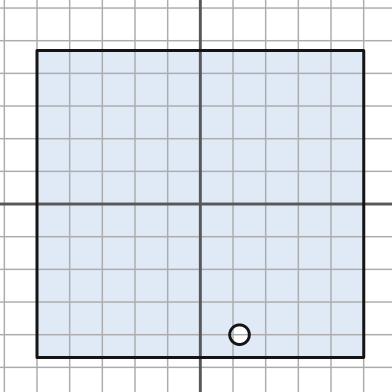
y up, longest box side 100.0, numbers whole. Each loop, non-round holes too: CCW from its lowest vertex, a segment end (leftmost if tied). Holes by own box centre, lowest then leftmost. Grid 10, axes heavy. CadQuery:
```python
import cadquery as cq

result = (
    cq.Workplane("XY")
    .moveTo(-50.0, -47.0)
    .lineTo(50.0, -47.0)
    .lineTo(50.0, 47.0)
    .lineTo(-50.0, 47.0)
    .close()
    .moveTo(12.0, -40.0)
    .circle(3.0)
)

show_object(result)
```